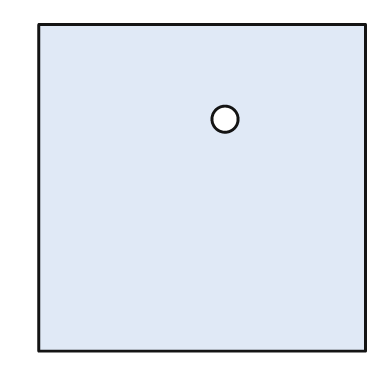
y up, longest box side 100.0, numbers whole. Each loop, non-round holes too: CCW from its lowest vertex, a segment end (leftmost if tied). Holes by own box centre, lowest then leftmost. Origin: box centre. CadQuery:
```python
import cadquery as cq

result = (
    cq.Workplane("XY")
    .moveTo(-50.0, -50.0)
    .lineTo(50.0, -50.0)
    .lineTo(50.0, 50.0)
    .lineTo(-50.0, 50.0)
    .close()
    .moveTo(7.0, 21.0)
    .circle(4.0)
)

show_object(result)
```